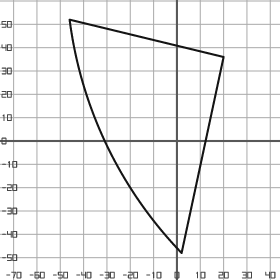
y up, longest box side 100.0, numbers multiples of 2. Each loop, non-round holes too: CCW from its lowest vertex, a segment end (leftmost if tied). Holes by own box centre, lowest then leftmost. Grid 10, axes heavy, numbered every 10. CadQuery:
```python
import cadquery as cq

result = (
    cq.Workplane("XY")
    .moveTo(2.0, -48.0)
    .lineTo(20.0, 36.0)
    .lineTo(-46.0, 52.0)
    .threePointArc((-30.0, -2.0), (2.0, -48.0))
    .close()
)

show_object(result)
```